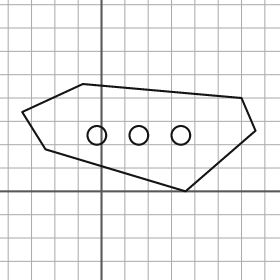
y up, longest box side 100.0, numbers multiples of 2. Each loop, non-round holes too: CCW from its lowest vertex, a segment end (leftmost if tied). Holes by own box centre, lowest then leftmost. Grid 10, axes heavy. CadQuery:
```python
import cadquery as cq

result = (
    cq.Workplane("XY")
    .moveTo(36.0, 0.0)
    .lineTo(66.0, 26.0)
    .lineTo(60.0, 40.0)
    .lineTo(-8.0, 46.0)
    .lineTo(-34.0, 34.0)
    .lineTo(-24.0, 18.0)
    .close()
    .moveTo(-2.0, 24.0)
    .circle(4.0)
    .moveTo(16.0, 24.0)
    .circle(4.0)
    .moveTo(34.0, 24.0)
    .circle(4.0)
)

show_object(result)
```